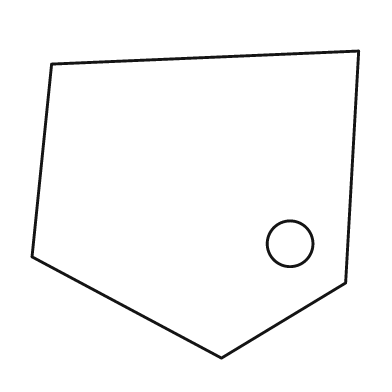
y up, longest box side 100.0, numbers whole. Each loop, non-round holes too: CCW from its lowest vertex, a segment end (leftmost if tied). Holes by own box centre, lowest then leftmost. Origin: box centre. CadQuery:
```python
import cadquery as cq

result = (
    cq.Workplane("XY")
    .moveTo(8.0, -47.0)
    .lineTo(46.0, -24.0)
    .lineTo(50.0, 47.0)
    .lineTo(-44.0, 43.0)
    .lineTo(-50.0, -16.0)
    .close()
    .moveTo(29.0, -12.0)
    .circle(7.0)
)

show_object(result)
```